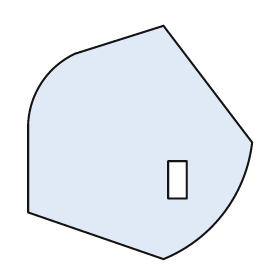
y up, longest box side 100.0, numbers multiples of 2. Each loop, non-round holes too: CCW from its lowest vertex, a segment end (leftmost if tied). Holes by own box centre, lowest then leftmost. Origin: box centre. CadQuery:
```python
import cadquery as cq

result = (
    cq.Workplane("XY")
    .moveTo(10.0, -50.0)
    .threePointArc((36.0, -30.0), (48.0, 0.0))
    .lineTo(10.0, 50.0)
    .lineTo(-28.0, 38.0)
    .threePointArc((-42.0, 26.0), (-48.0, 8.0))
    .lineTo(-48.0, -30.0)
    .close()
    .moveTo(12.0, -24.0)
    .lineTo(20.0, -24.0)
    .lineTo(20.0, -8.0)
    .lineTo(12.0, -8.0)
    .close()
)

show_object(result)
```